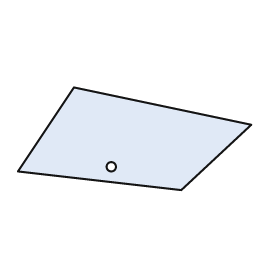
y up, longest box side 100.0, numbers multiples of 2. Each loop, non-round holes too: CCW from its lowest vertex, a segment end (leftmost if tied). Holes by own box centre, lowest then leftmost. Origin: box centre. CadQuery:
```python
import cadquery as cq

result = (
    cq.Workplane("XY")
    .moveTo(20.0, -22.0)
    .lineTo(50.0, 6.0)
    .lineTo(-26.0, 22.0)
    .lineTo(-50.0, -14.0)
    .close()
    .moveTo(-10.0, -12.0)
    .circle(2.0)
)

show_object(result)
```